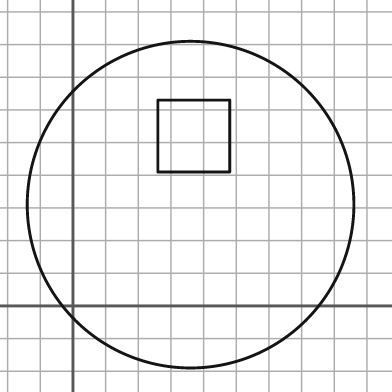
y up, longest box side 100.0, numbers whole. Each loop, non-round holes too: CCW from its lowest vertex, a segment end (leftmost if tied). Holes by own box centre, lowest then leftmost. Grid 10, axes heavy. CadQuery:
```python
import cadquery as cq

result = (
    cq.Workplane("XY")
    .moveTo(36.0, 31.0)
    .circle(50.0)
    .moveTo(26.0, 41.0)
    .lineTo(48.0, 41.0)
    .lineTo(48.0, 63.0)
    .lineTo(26.0, 63.0)
    .close()
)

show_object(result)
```